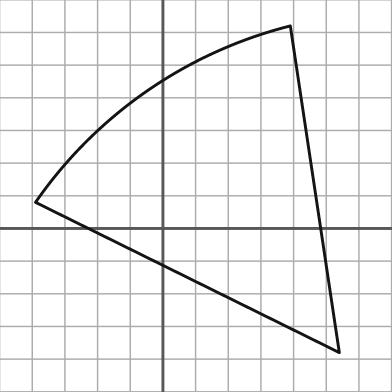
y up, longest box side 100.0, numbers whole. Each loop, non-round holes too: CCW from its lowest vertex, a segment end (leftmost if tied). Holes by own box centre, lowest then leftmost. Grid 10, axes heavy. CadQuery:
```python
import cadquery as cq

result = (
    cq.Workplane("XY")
    .moveTo(54.0, -38.0)
    .lineTo(39.0, 62.0)
    .threePointArc((-5.0, 42.0), (-39.0, 8.0))
    .close()
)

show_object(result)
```